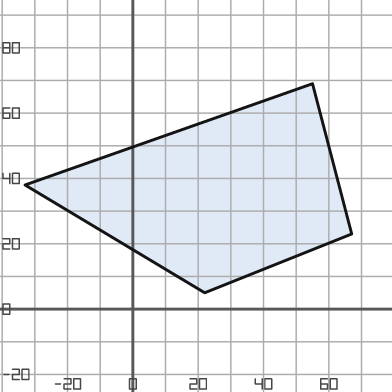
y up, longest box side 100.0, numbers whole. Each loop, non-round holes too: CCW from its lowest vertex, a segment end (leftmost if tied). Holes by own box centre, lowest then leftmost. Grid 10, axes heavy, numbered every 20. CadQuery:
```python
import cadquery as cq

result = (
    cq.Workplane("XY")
    .moveTo(22.0, 5.0)
    .lineTo(67.0, 23.0)
    .lineTo(55.0, 69.0)
    .lineTo(-33.0, 38.0)
    .close()
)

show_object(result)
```